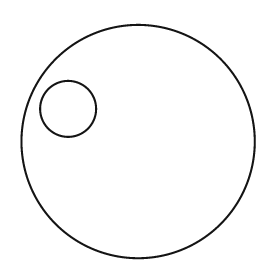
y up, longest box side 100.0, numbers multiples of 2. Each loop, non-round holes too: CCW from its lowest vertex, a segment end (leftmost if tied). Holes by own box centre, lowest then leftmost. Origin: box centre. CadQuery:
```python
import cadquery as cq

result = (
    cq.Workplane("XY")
    .moveTo(0.0, 0.0)
    .circle(50.0)
    .moveTo(-30.0, 14.0)
    .circle(12.0)
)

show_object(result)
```